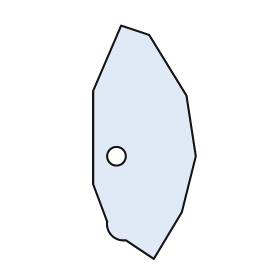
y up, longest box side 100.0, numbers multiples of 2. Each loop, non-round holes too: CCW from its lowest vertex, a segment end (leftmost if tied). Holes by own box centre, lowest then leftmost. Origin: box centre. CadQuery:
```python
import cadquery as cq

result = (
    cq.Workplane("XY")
    .moveTo(4.0, -50.0)
    .lineTo(16.0, -30.0)
    .lineTo(22.0, -6.0)
    .lineTo(18.0, 20.0)
    .lineTo(2.0, 46.0)
    .lineTo(-10.0, 50.0)
    .lineTo(-22.0, 22.0)
    .lineTo(-22.0, -18.0)
    .lineTo(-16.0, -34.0)
    .threePointArc((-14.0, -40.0), (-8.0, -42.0))
    .close()
    .moveTo(-12.0, -6.0)
    .circle(4.0)
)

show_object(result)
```